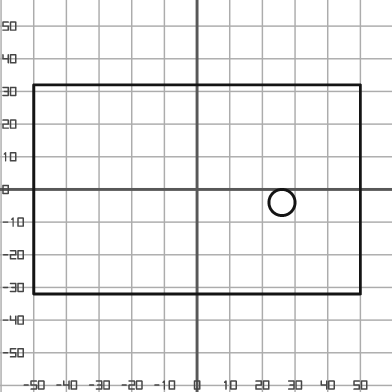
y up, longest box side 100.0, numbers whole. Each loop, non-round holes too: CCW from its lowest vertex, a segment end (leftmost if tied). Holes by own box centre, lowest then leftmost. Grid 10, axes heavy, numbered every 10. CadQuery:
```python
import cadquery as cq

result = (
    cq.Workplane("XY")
    .moveTo(-50.0, -32.0)
    .lineTo(50.0, -32.0)
    .lineTo(50.0, 32.0)
    .lineTo(-50.0, 32.0)
    .close()
    .moveTo(26.0, -4.0)
    .circle(4.0)
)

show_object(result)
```